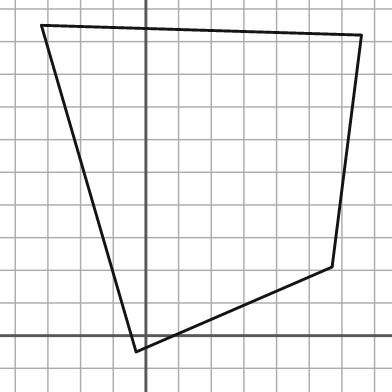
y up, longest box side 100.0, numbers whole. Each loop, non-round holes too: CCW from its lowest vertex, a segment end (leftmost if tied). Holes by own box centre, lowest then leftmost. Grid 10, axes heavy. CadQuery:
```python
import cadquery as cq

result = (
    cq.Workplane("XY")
    .moveTo(-3.0, -5.0)
    .lineTo(57.0, 21.0)
    .lineTo(66.0, 92.0)
    .lineTo(-32.0, 95.0)
    .close()
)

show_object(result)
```